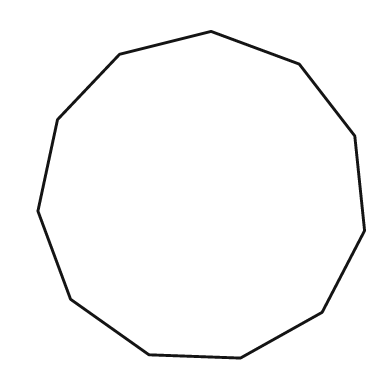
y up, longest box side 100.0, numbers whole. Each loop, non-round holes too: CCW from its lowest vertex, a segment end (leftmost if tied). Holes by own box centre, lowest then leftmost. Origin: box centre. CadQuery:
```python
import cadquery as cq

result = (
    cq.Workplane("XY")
    .moveTo(12.0, -50.0)
    .lineTo(37.0, -36.0)
    .lineTo(50.0, -11.0)
    .lineTo(47.0, 18.0)
    .lineTo(30.0, 40.0)
    .lineTo(3.0, 50.0)
    .lineTo(-25.0, 43.0)
    .lineTo(-44.0, 23.0)
    .lineTo(-50.0, -5.0)
    .lineTo(-40.0, -32.0)
    .lineTo(-16.0, -49.0)
    .close()
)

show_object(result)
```